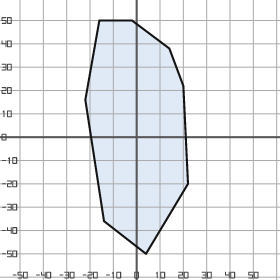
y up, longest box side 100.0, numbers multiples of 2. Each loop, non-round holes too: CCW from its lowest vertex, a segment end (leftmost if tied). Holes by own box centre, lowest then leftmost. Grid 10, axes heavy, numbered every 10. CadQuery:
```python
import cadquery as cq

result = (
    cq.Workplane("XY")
    .moveTo(4.0, -50.0)
    .lineTo(22.0, -20.0)
    .lineTo(20.0, 22.0)
    .lineTo(14.0, 38.0)
    .lineTo(-2.0, 50.0)
    .lineTo(-16.0, 50.0)
    .lineTo(-22.0, 16.0)
    .lineTo(-14.0, -36.0)
    .close()
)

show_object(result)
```